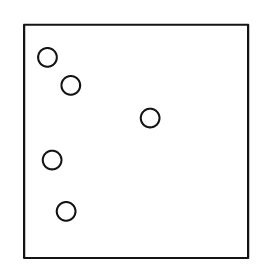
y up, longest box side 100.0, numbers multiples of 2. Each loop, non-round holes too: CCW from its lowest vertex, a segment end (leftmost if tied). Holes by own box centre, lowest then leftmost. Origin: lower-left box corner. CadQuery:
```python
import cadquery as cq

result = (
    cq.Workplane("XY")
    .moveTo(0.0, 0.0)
    .lineTo(96.0, 0.0)
    .lineTo(96.0, 100.0)
    .lineTo(0.0, 100.0)
    .close()
    .moveTo(18.0, 20.0)
    .circle(4.0)
    .moveTo(12.0, 42.0)
    .circle(4.0)
    .moveTo(54.0, 60.0)
    .circle(4.0)
    .moveTo(20.0, 74.0)
    .circle(4.0)
    .moveTo(10.0, 86.0)
    .circle(4.0)
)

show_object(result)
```